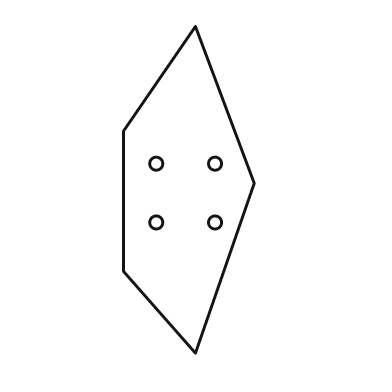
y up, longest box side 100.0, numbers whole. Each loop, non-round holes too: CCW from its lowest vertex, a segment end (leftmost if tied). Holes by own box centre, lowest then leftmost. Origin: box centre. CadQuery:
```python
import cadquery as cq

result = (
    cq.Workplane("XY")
    .moveTo(2.0, -50.0)
    .lineTo(20.0, 2.0)
    .lineTo(2.0, 50.0)
    .lineTo(-20.0, 18.0)
    .lineTo(-20.0, -25.0)
    .close()
    .moveTo(-10.0, -10.0)
    .circle(2.0)
    .moveTo(8.0, -10.0)
    .circle(2.0)
    .moveTo(-10.0, 8.0)
    .circle(2.0)
    .moveTo(8.0, 8.0)
    .circle(2.0)
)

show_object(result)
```